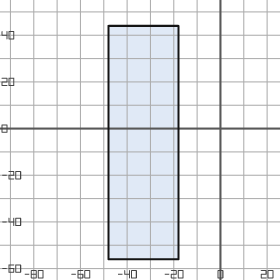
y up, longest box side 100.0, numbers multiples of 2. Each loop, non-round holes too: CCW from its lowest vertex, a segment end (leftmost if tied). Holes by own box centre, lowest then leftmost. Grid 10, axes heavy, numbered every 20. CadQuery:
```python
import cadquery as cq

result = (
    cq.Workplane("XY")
    .moveTo(-48.0, -56.0)
    .lineTo(-18.0, -56.0)
    .lineTo(-18.0, 44.0)
    .lineTo(-48.0, 44.0)
    .close()
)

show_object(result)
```